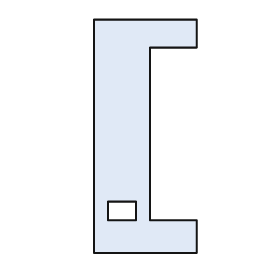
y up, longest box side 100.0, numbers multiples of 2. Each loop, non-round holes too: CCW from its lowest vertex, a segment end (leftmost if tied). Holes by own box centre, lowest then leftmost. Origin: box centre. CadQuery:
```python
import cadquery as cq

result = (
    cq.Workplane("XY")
    .moveTo(-22.0, -50.0)
    .lineTo(22.0, -50.0)
    .lineTo(22.0, -36.0)
    .lineTo(2.0, -36.0)
    .lineTo(2.0, 38.0)
    .lineTo(22.0, 38.0)
    .lineTo(22.0, 50.0)
    .lineTo(-22.0, 50.0)
    .close()
    .moveTo(-16.0, -36.0)
    .lineTo(-4.0, -36.0)
    .lineTo(-4.0, -28.0)
    .lineTo(-16.0, -28.0)
    .close()
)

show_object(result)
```